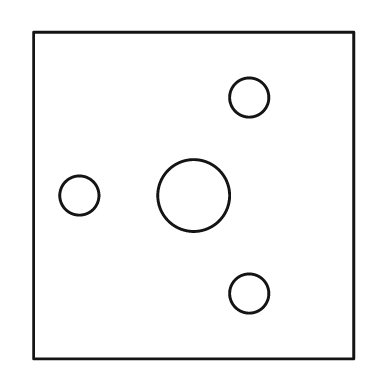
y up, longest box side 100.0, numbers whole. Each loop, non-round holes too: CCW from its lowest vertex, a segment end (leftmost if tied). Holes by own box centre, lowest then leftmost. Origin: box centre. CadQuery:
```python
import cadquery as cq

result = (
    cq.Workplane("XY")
    .moveTo(-49.0, -50.0)
    .lineTo(49.0, -50.0)
    .lineTo(49.0, 50.0)
    .lineTo(-49.0, 50.0)
    .close()
    .moveTo(17.0, -30.0)
    .circle(6.0)
    .moveTo(-35.0, 0.0)
    .circle(6.0)
    .moveTo(0.0, 0.0)
    .circle(11.0)
    .moveTo(17.0, 30.0)
    .circle(6.0)
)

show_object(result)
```